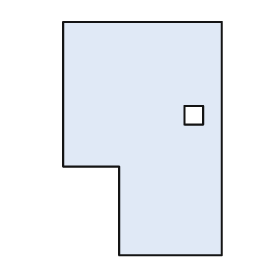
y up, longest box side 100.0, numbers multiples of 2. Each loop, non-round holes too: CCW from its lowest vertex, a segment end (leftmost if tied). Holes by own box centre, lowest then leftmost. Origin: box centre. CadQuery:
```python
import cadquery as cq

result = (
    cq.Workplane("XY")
    .moveTo(-10.0, -50.0)
    .lineTo(34.0, -50.0)
    .lineTo(34.0, 50.0)
    .lineTo(-34.0, 50.0)
    .lineTo(-34.0, -12.0)
    .lineTo(-10.0, -12.0)
    .close()
    .moveTo(18.0, 6.0)
    .lineTo(26.0, 6.0)
    .lineTo(26.0, 14.0)
    .lineTo(18.0, 14.0)
    .close()
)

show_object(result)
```